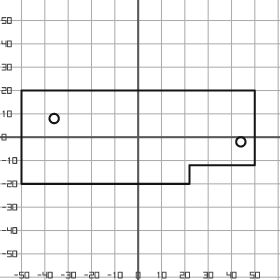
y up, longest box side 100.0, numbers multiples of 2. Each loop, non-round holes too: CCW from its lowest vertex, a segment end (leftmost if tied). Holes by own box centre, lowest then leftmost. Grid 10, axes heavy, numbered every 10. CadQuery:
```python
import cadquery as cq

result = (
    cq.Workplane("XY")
    .moveTo(-50.0, -20.0)
    .lineTo(22.0, -20.0)
    .lineTo(22.0, -12.0)
    .lineTo(50.0, -12.0)
    .lineTo(50.0, 20.0)
    .lineTo(-50.0, 20.0)
    .close()
    .moveTo(44.0, -2.0)
    .circle(2.0)
    .moveTo(-36.0, 8.0)
    .circle(2.0)
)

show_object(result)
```